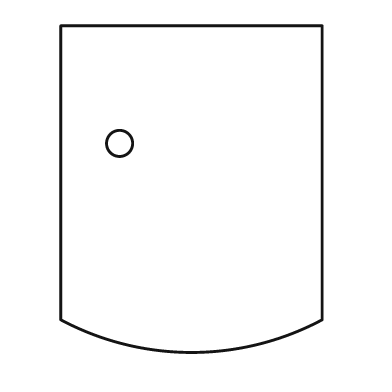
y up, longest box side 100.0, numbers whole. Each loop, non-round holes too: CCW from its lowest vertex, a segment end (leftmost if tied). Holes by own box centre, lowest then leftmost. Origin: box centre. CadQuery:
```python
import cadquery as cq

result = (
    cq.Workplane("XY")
    .moveTo(-40.0, -40.0)
    .threePointArc((0.0, -50.0), (40.0, -40.0))
    .lineTo(40.0, 50.0)
    .lineTo(-40.0, 50.0)
    .close()
    .moveTo(-22.0, 14.0)
    .circle(4.0)
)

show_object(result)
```